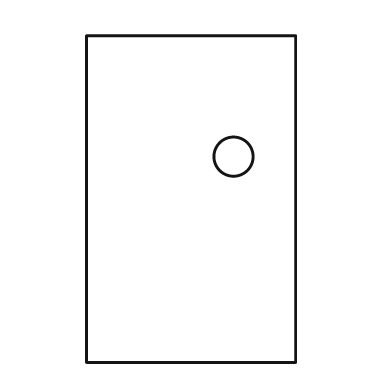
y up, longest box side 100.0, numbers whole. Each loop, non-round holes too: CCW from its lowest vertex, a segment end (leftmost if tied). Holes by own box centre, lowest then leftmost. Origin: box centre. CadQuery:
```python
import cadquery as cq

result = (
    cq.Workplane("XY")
    .moveTo(-32.0, -50.0)
    .lineTo(32.0, -50.0)
    .lineTo(32.0, 50.0)
    .lineTo(-32.0, 50.0)
    .close()
    .moveTo(13.0, 13.0)
    .circle(6.0)
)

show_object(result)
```